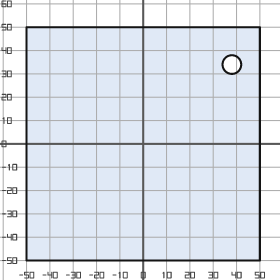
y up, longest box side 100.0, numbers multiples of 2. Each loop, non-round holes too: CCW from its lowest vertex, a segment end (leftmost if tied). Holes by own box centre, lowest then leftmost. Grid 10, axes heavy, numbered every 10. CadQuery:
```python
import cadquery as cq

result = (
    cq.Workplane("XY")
    .moveTo(-50.0, -50.0)
    .lineTo(50.0, -50.0)
    .lineTo(50.0, 50.0)
    .lineTo(-50.0, 50.0)
    .close()
    .moveTo(38.0, 34.0)
    .circle(4.0)
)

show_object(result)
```